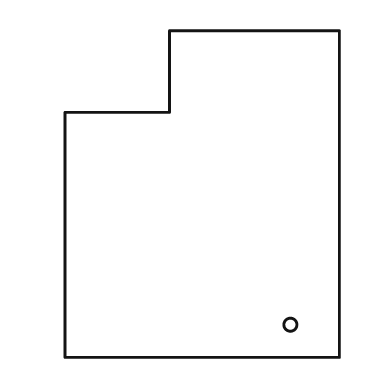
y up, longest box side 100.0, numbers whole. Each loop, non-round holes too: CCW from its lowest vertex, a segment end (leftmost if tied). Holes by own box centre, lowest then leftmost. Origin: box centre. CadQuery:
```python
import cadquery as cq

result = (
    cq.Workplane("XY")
    .moveTo(-42.0, -50.0)
    .lineTo(42.0, -50.0)
    .lineTo(42.0, 50.0)
    .lineTo(-10.0, 50.0)
    .lineTo(-10.0, 25.0)
    .lineTo(-42.0, 25.0)
    .close()
    .moveTo(27.0, -40.0)
    .circle(2.0)
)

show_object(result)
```